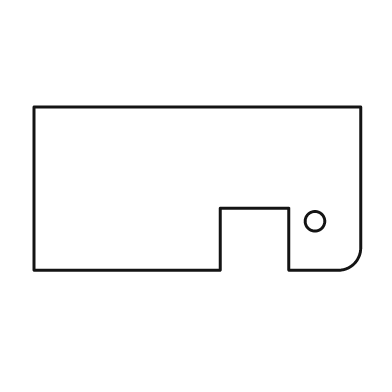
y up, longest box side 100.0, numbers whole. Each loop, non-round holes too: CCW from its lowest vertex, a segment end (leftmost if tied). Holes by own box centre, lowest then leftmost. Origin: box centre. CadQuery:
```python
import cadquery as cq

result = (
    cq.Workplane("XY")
    .moveTo(-50.0, -25.0)
    .lineTo(7.0, -25.0)
    .lineTo(7.0, -6.0)
    .lineTo(28.0, -6.0)
    .lineTo(28.0, -25.0)
    .lineTo(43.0, -25.0)
    .threePointArc((48.0, -23.0), (50.0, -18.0))
    .lineTo(50.0, 25.0)
    .lineTo(-50.0, 25.0)
    .close()
    .moveTo(36.0, -10.0)
    .circle(3.0)
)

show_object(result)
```